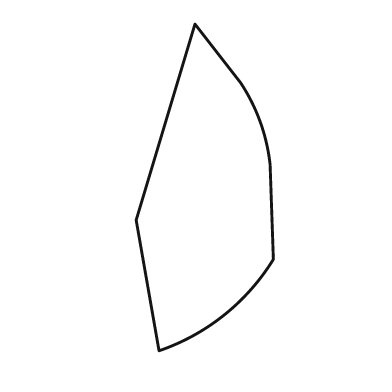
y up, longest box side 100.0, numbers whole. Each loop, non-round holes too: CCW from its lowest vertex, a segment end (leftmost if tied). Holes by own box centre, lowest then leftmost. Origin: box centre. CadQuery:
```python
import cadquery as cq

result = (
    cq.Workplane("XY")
    .moveTo(-14.0, -50.0)
    .threePointArc((6.0, -39.0), (21.0, -22.0))
    .lineTo(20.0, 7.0)
    .threePointArc((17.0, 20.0), (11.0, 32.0))
    .lineTo(-3.0, 50.0)
    .lineTo(-21.0, -10.0)
    .close()
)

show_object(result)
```